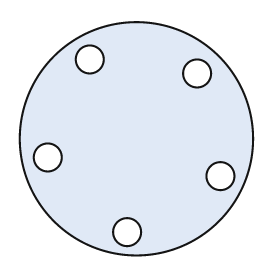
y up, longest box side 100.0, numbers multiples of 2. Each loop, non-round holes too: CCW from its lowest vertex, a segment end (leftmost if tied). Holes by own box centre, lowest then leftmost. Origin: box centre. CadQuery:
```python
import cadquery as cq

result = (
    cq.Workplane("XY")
    .moveTo(0.0, 0.0)
    .circle(50.0)
    .moveTo(-4.0, -40.0)
    .circle(6.0)
    .moveTo(36.0, -16.0)
    .circle(6.0)
    .moveTo(-38.0, -8.0)
    .circle(6.0)
    .moveTo(26.0, 28.0)
    .circle(6.0)
    .moveTo(-20.0, 34.0)
    .circle(6.0)
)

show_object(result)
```